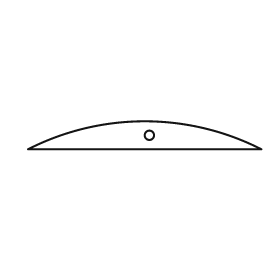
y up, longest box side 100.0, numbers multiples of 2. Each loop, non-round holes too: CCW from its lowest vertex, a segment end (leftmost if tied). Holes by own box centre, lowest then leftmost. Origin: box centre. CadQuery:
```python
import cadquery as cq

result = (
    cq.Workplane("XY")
    .moveTo(-50.0, -6.0)
    .lineTo(50.0, -6.0)
    .threePointArc((0.0, 6.0), (-50.0, -6.0))
    .close()
    .moveTo(2.0, 0.0)
    .circle(2.0)
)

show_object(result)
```